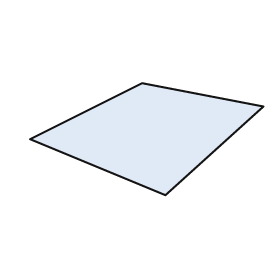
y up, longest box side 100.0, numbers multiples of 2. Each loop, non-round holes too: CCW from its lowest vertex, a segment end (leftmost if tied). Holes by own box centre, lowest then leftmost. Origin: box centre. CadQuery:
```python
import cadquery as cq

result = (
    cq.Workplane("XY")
    .moveTo(8.0, -24.0)
    .lineTo(50.0, 14.0)
    .lineTo(-2.0, 24.0)
    .lineTo(-50.0, 0.0)
    .close()
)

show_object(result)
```